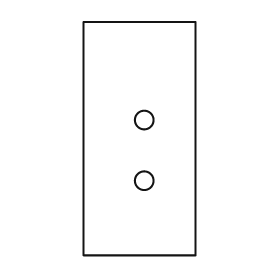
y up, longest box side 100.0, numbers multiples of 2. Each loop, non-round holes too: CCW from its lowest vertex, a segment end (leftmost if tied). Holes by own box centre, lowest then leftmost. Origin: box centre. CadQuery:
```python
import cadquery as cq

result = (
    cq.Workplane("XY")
    .moveTo(-24.0, -50.0)
    .lineTo(24.0, -50.0)
    .lineTo(24.0, 50.0)
    .lineTo(-24.0, 50.0)
    .close()
    .moveTo(2.0, -18.0)
    .circle(4.0)
    .moveTo(2.0, 8.0)
    .circle(4.0)
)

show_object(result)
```